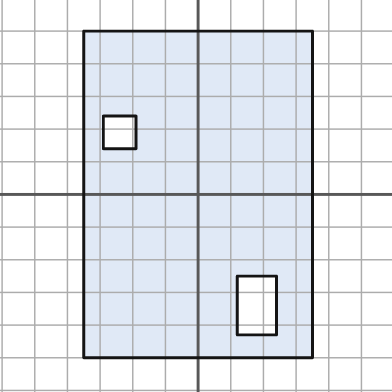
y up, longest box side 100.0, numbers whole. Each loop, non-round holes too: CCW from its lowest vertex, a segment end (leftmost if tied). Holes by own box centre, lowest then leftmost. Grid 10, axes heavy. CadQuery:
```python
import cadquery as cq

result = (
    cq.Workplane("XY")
    .moveTo(-35.0, -50.0)
    .lineTo(35.0, -50.0)
    .lineTo(35.0, 50.0)
    .lineTo(-35.0, 50.0)
    .close()
    .moveTo(12.0, -43.0)
    .lineTo(24.0, -43.0)
    .lineTo(24.0, -25.0)
    .lineTo(12.0, -25.0)
    .close()
    .moveTo(-29.0, 14.0)
    .lineTo(-19.0, 14.0)
    .lineTo(-19.0, 24.0)
    .lineTo(-29.0, 24.0)
    .close()
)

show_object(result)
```